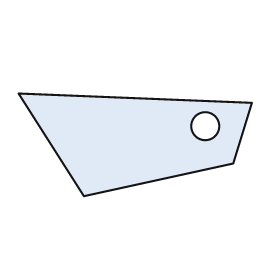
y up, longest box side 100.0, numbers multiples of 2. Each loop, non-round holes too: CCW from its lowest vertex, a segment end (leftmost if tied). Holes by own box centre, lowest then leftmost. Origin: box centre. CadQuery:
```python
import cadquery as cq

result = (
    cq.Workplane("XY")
    .moveTo(-22.0, -22.0)
    .lineTo(42.0, -8.0)
    .lineTo(50.0, 18.0)
    .lineTo(-50.0, 22.0)
    .close()
    .moveTo(30.0, 8.0)
    .circle(6.0)
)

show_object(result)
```